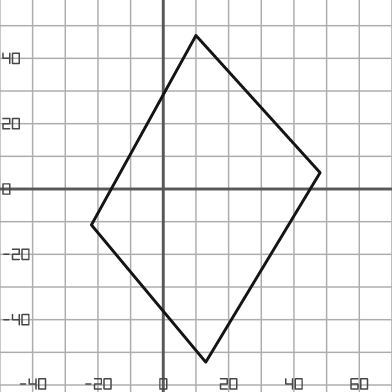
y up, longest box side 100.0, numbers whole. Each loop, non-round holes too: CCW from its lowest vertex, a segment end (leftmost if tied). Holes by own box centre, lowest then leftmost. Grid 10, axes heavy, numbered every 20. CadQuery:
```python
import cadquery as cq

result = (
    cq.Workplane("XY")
    .moveTo(13.0, -53.0)
    .lineTo(48.0, 5.0)
    .lineTo(10.0, 47.0)
    .lineTo(-22.0, -11.0)
    .close()
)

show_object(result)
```